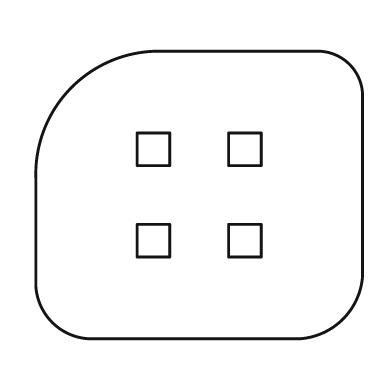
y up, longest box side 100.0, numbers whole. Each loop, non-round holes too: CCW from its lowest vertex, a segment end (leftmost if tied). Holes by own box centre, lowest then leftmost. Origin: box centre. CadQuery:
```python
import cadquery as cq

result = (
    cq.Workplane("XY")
    .moveTo(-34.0, -44.0)
    .lineTo(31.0, -44.0)
    .threePointArc((44.0, -38.0), (50.0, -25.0))
    .lineTo(50.0, 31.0)
    .threePointArc((46.0, 40.0), (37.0, 44.0))
    .lineTo(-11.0, 44.0)
    .threePointArc((-39.0, 33.0), (-50.0, 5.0))
    .lineTo(-50.0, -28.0)
    .threePointArc((-45.0, -39.0), (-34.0, -44.0))
    .close()
    .moveTo(-19.0, -19.0)
    .lineTo(-9.0, -19.0)
    .lineTo(-9.0, -9.0)
    .lineTo(-19.0, -9.0)
    .close()
    .moveTo(9.0, -19.0)
    .lineTo(19.0, -19.0)
    .lineTo(19.0, -9.0)
    .lineTo(9.0, -9.0)
    .close()
    .moveTo(-19.0, 9.0)
    .lineTo(-9.0, 9.0)
    .lineTo(-9.0, 19.0)
    .lineTo(-19.0, 19.0)
    .close()
    .moveTo(9.0, 9.0)
    .lineTo(19.0, 9.0)
    .lineTo(19.0, 19.0)
    .lineTo(9.0, 19.0)
    .close()
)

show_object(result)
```